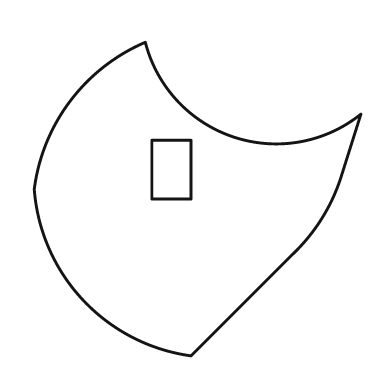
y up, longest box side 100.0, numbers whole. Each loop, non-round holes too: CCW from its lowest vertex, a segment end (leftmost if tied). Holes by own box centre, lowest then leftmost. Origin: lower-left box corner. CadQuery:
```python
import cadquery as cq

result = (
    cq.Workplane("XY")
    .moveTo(48.0, 0.0)
    .lineTo(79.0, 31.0)
    .threePointArc((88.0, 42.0), (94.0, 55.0))
    .lineTo(100.0, 74.0)
    .threePointArc((61.0, 67.0), (34.0, 96.0))
    .threePointArc((11.0, 78.0), (0.0, 51.0))
    .threePointArc((15.0, 17.0), (48.0, 0.0))
    .close()
    .moveTo(36.0, 48.0)
    .lineTo(48.0, 48.0)
    .lineTo(48.0, 66.0)
    .lineTo(36.0, 66.0)
    .close()
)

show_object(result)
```